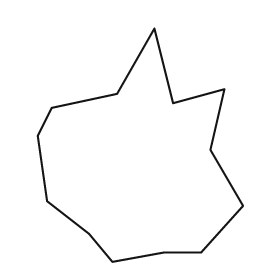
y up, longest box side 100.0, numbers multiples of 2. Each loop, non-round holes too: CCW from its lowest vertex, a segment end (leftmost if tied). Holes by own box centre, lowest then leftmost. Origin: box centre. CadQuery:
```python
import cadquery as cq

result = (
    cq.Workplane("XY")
    .moveTo(-12.0, -50.0)
    .lineTo(10.0, -46.0)
    .lineTo(26.0, -46.0)
    .lineTo(44.0, -26.0)
    .lineTo(30.0, -2.0)
    .lineTo(36.0, 24.0)
    .lineTo(14.0, 18.0)
    .lineTo(6.0, 50.0)
    .lineTo(-10.0, 22.0)
    .lineTo(-38.0, 16.0)
    .lineTo(-44.0, 4.0)
    .lineTo(-40.0, -24.0)
    .lineTo(-22.0, -38.0)
    .close()
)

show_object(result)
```